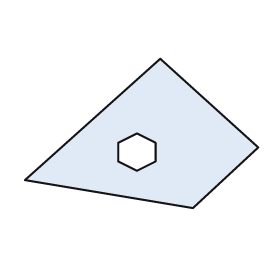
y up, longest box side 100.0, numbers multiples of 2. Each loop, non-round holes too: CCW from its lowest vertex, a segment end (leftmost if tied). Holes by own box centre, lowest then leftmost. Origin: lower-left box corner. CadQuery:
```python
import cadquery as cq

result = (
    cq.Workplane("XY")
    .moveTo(72.0, 0.0)
    .lineTo(100.0, 26.0)
    .lineTo(58.0, 64.0)
    .lineTo(0.0, 12.0)
    .close()
    .moveTo(48.0, 16.0)
    .lineTo(56.0, 20.0)
    .lineTo(56.0, 28.0)
    .lineTo(48.0, 32.0)
    .lineTo(40.0, 28.0)
    .lineTo(40.0, 20.0)
    .close()
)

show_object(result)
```